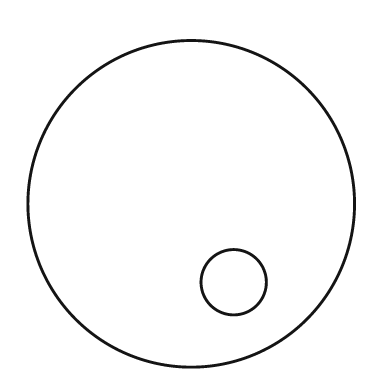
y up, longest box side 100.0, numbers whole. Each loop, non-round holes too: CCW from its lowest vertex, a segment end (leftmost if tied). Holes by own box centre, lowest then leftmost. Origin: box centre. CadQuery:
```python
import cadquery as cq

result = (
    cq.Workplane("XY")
    .moveTo(0.0, 0.0)
    .circle(50.0)
    .moveTo(13.0, -24.0)
    .circle(10.0)
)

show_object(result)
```